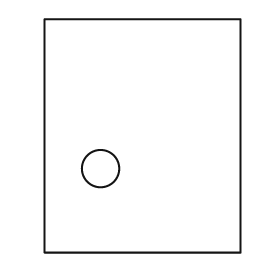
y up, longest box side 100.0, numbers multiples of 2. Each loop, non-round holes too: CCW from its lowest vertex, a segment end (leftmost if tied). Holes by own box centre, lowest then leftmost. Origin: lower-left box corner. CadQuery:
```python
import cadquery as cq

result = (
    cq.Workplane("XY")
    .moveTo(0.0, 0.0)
    .lineTo(84.0, 0.0)
    .lineTo(84.0, 100.0)
    .lineTo(0.0, 100.0)
    .close()
    .moveTo(24.0, 36.0)
    .circle(8.0)
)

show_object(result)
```